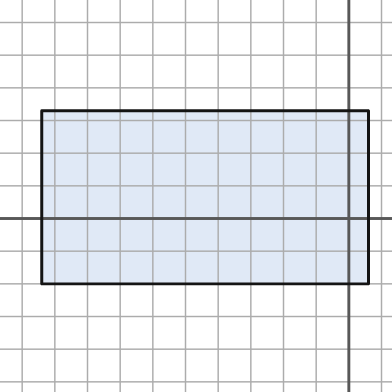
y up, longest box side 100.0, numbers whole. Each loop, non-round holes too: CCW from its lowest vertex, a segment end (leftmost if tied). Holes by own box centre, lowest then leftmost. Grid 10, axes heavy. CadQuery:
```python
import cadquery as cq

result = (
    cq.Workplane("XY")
    .moveTo(-94.0, -20.0)
    .lineTo(6.0, -20.0)
    .lineTo(6.0, 33.0)
    .lineTo(-94.0, 33.0)
    .close()
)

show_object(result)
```